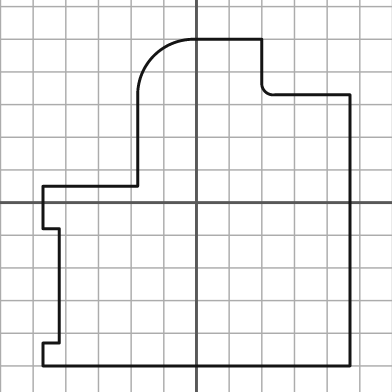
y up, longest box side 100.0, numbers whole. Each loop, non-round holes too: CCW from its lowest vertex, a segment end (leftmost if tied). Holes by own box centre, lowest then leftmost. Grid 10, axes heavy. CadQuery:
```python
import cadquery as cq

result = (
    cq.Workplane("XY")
    .moveTo(-47.0, -50.0)
    .lineTo(47.0, -50.0)
    .lineTo(47.0, 33.0)
    .lineTo(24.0, 33.0)
    .threePointArc((21.0, 34.0), (20.0, 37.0))
    .lineTo(20.0, 50.0)
    .lineTo(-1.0, 50.0)
    .threePointArc((-13.0, 45.0), (-18.0, 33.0))
    .lineTo(-18.0, 5.0)
    .lineTo(-47.0, 5.0)
    .lineTo(-47.0, -8.0)
    .lineTo(-42.0, -8.0)
    .lineTo(-42.0, -43.0)
    .lineTo(-47.0, -43.0)
    .close()
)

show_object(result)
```